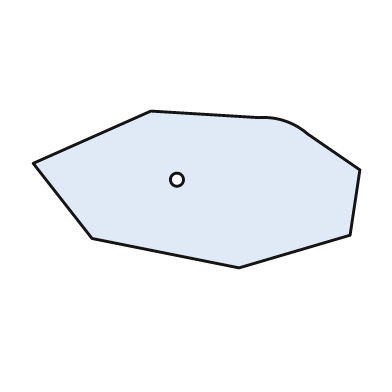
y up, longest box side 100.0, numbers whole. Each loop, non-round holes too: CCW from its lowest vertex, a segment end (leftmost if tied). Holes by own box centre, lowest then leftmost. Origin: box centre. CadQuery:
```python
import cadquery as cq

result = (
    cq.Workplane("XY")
    .moveTo(13.0, -24.0)
    .lineTo(47.0, -14.0)
    .lineTo(50.0, 6.0)
    .lineTo(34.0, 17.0)
    .threePointArc((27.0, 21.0), (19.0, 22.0))
    .lineTo(-14.0, 24.0)
    .lineTo(-50.0, 8.0)
    .lineTo(-32.0, -15.0)
    .close()
    .moveTo(-6.0, 3.0)
    .circle(2.0)
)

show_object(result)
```